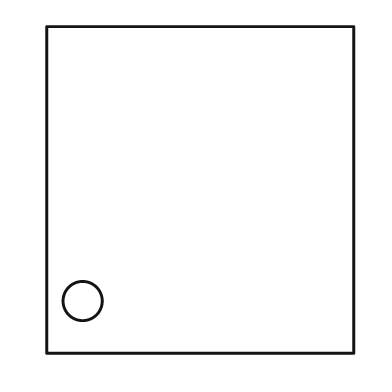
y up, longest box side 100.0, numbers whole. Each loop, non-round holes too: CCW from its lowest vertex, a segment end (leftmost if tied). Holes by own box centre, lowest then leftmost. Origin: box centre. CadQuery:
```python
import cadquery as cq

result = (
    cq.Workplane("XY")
    .moveTo(-47.0, -50.0)
    .lineTo(47.0, -50.0)
    .lineTo(47.0, 50.0)
    .lineTo(-47.0, 50.0)
    .close()
    .moveTo(-36.0, -34.0)
    .circle(6.0)
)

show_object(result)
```